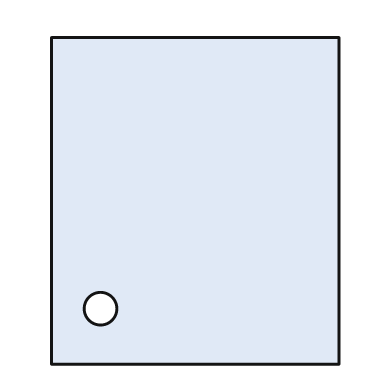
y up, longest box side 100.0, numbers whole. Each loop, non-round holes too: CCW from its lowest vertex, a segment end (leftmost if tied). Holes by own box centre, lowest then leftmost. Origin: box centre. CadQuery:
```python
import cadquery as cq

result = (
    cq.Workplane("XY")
    .moveTo(-44.0, -50.0)
    .lineTo(44.0, -50.0)
    .lineTo(44.0, 50.0)
    .lineTo(-44.0, 50.0)
    .close()
    .moveTo(-29.0, -33.0)
    .circle(5.0)
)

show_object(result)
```